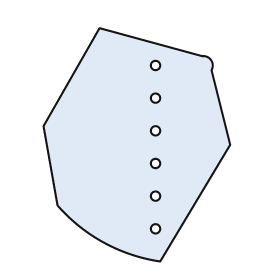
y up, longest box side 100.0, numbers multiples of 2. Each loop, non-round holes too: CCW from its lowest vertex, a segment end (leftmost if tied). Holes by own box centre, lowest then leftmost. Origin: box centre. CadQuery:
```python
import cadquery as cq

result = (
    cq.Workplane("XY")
    .moveTo(10.0, -50.0)
    .lineTo(40.0, 0.0)
    .lineTo(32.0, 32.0)
    .threePointArc((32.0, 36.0), (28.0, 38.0))
    .lineTo(-16.0, 50.0)
    .lineTo(-40.0, 8.0)
    .lineTo(-34.0, -26.0)
    .threePointArc((-14.0, -42.0), (10.0, -50.0))
    .close()
    .moveTo(8.0, -36.0)
    .circle(2.0)
    .moveTo(8.0, -22.0)
    .circle(2.0)
    .moveTo(8.0, -8.0)
    .circle(2.0)
    .moveTo(8.0, 6.0)
    .circle(2.0)
    .moveTo(8.0, 20.0)
    .circle(2.0)
    .moveTo(8.0, 34.0)
    .circle(2.0)
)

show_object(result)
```